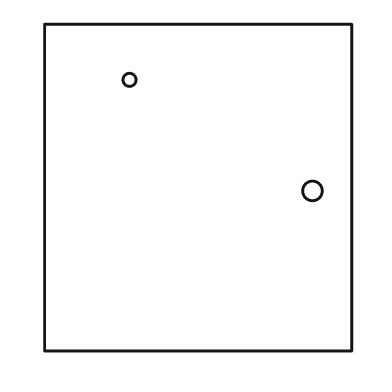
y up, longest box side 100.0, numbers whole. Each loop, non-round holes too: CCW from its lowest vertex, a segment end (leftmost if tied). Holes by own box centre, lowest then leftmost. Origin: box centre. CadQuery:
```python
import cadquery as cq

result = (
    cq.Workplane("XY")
    .moveTo(-47.0, -50.0)
    .lineTo(47.0, -50.0)
    .lineTo(47.0, 50.0)
    .lineTo(-47.0, 50.0)
    .close()
    .moveTo(35.0, -1.0)
    .circle(3.0)
    .moveTo(-21.0, 33.0)
    .circle(2.0)
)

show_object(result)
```